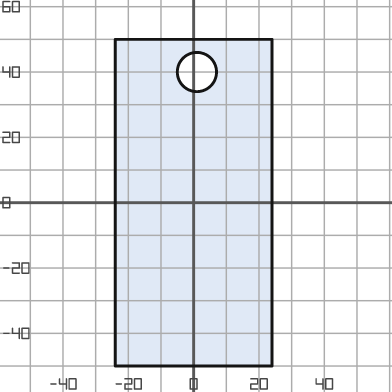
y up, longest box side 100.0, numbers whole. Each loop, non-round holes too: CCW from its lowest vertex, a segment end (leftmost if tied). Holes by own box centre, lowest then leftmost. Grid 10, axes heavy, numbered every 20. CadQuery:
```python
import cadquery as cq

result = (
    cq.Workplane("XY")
    .moveTo(-24.0, -50.0)
    .lineTo(24.0, -50.0)
    .lineTo(24.0, 50.0)
    .lineTo(-24.0, 50.0)
    .close()
    .moveTo(1.0, 40.0)
    .circle(6.0)
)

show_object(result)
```